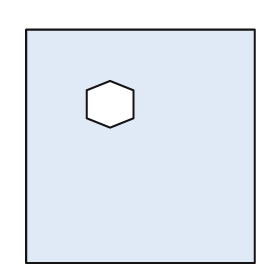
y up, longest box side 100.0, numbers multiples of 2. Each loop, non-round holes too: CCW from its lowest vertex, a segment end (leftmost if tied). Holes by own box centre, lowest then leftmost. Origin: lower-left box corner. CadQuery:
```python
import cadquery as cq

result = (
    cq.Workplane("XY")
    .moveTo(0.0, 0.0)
    .lineTo(98.0, 0.0)
    .lineTo(98.0, 100.0)
    .lineTo(0.0, 100.0)
    .close()
    .moveTo(36.0, 58.0)
    .lineTo(46.0, 62.0)
    .lineTo(46.0, 74.0)
    .lineTo(36.0, 78.0)
    .lineTo(26.0, 74.0)
    .lineTo(26.0, 62.0)
    .close()
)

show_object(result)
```